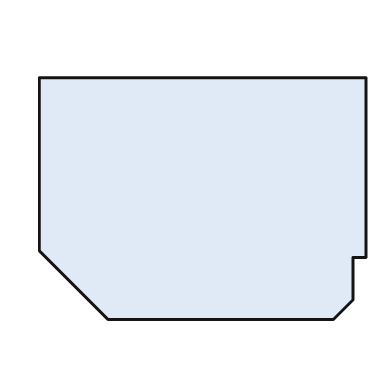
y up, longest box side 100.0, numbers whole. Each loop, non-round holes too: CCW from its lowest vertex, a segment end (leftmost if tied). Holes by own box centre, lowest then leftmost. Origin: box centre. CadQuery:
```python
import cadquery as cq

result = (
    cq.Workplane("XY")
    .moveTo(-29.0, -37.0)
    .lineTo(40.0, -37.0)
    .lineTo(46.0, -31.0)
    .lineTo(46.0, -18.0)
    .lineTo(50.0, -18.0)
    .lineTo(50.0, 37.0)
    .lineTo(-50.0, 37.0)
    .lineTo(-50.0, -16.0)
    .close()
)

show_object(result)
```